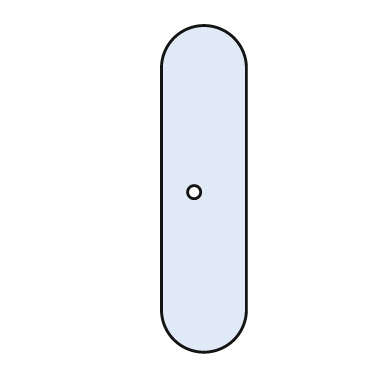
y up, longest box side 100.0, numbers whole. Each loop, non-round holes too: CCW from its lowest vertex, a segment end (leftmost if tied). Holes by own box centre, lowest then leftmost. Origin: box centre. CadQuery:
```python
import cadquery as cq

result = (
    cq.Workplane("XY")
    .moveTo(-13.0, -37.0)
    .threePointArc((0.0, -50.0), (13.0, -37.0))
    .lineTo(13.0, 37.0)
    .threePointArc((0.0, 50.0), (-13.0, 37.0))
    .close()
    .moveTo(-3.0, -1.0)
    .circle(2.0)
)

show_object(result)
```